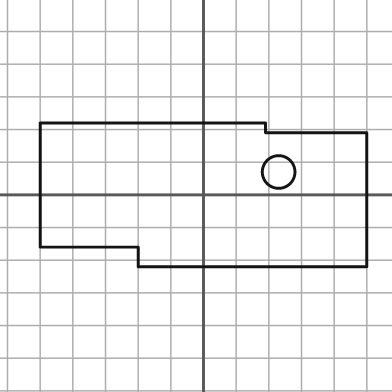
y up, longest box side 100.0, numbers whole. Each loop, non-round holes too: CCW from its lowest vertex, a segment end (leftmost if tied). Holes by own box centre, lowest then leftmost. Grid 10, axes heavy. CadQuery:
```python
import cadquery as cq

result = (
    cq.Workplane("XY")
    .moveTo(-20.0, -22.0)
    .lineTo(50.0, -22.0)
    .lineTo(50.0, 19.0)
    .lineTo(19.0, 19.0)
    .lineTo(19.0, 22.0)
    .lineTo(-50.0, 22.0)
    .lineTo(-50.0, -16.0)
    .lineTo(-20.0, -16.0)
    .close()
    .moveTo(23.0, 7.0)
    .circle(5.0)
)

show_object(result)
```